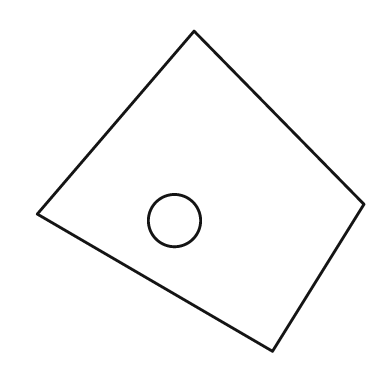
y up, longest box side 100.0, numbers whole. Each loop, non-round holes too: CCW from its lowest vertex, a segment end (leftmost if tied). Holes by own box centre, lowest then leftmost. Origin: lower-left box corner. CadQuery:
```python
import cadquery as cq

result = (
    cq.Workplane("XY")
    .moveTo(72.0, 0.0)
    .lineTo(100.0, 45.0)
    .lineTo(48.0, 98.0)
    .lineTo(0.0, 42.0)
    .close()
    .moveTo(42.0, 40.0)
    .circle(8.0)
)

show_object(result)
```